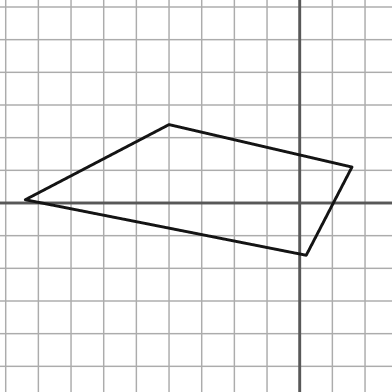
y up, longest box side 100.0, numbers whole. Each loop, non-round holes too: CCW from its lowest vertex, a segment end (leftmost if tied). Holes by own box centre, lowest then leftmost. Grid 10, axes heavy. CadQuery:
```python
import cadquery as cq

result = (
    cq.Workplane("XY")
    .moveTo(2.0, -16.0)
    .lineTo(16.0, 11.0)
    .lineTo(-40.0, 24.0)
    .lineTo(-84.0, 1.0)
    .close()
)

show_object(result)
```